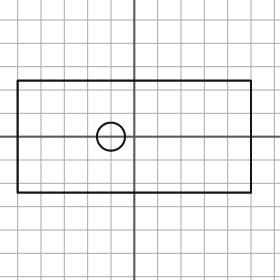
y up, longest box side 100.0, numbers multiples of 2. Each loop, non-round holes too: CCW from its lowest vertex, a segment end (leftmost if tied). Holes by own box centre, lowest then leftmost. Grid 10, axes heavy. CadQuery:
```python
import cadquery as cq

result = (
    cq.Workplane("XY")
    .moveTo(-50.0, -24.0)
    .lineTo(50.0, -24.0)
    .lineTo(50.0, 24.0)
    .lineTo(-50.0, 24.0)
    .close()
    .moveTo(-10.0, 0.0)
    .circle(6.0)
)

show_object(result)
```